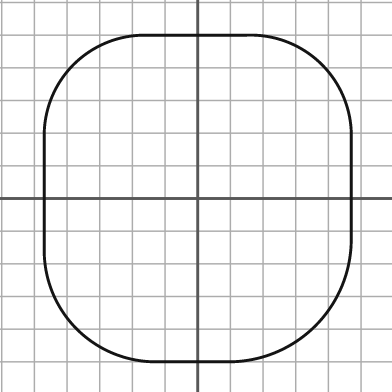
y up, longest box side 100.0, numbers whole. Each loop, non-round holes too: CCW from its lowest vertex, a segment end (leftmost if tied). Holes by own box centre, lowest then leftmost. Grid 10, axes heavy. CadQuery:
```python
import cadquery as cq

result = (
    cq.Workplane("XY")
    .moveTo(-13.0, -50.0)
    .lineTo(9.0, -50.0)
    .threePointArc((36.0, -39.0), (47.0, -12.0))
    .lineTo(47.0, 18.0)
    .threePointArc((38.0, 41.0), (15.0, 50.0))
    .lineTo(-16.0, 50.0)
    .threePointArc((-38.0, 41.0), (-47.0, 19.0))
    .lineTo(-47.0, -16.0)
    .threePointArc((-37.0, -40.0), (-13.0, -50.0))
    .close()
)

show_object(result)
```